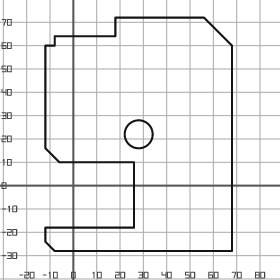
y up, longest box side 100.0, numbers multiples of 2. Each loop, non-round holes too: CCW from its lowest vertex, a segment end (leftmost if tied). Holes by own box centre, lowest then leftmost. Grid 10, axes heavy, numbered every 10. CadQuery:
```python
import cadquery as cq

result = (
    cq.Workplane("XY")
    .moveTo(-8.0, -28.0)
    .lineTo(68.0, -28.0)
    .lineTo(68.0, 60.0)
    .lineTo(56.0, 72.0)
    .lineTo(18.0, 72.0)
    .lineTo(18.0, 64.0)
    .lineTo(-8.0, 64.0)
    .lineTo(-8.0, 60.0)
    .lineTo(-12.0, 60.0)
    .lineTo(-12.0, 16.0)
    .lineTo(-6.0, 10.0)
    .lineTo(26.0, 10.0)
    .lineTo(26.0, -18.0)
    .lineTo(-12.0, -18.0)
    .lineTo(-12.0, -24.0)
    .close()
    .moveTo(28.0, 22.0)
    .circle(6.0)
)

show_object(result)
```